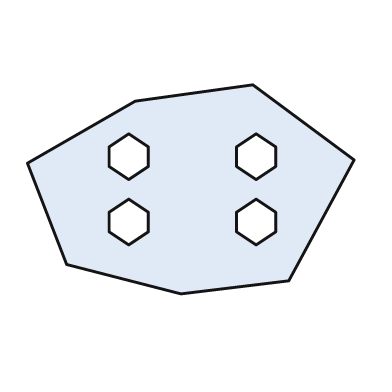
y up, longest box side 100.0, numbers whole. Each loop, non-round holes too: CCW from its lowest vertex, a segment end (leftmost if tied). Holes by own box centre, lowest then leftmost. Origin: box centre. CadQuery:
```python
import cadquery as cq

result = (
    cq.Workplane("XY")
    .moveTo(-3.0, -32.0)
    .lineTo(30.0, -28.0)
    .lineTo(50.0, 9.0)
    .lineTo(19.0, 32.0)
    .lineTo(-17.0, 27.0)
    .lineTo(-50.0, 8.0)
    .lineTo(-38.0, -23.0)
    .close()
    .moveTo(-19.0, -17.0)
    .lineTo(-13.0, -13.0)
    .lineTo(-13.0, -7.0)
    .lineTo(-19.0, -3.0)
    .lineTo(-25.0, -7.0)
    .lineTo(-25.0, -13.0)
    .close()
    .moveTo(20.0, -17.0)
    .lineTo(26.0, -13.0)
    .lineTo(26.0, -7.0)
    .lineTo(20.0, -3.0)
    .lineTo(14.0, -7.0)
    .lineTo(14.0, -13.0)
    .close()
    .moveTo(-19.0, 3.0)
    .lineTo(-13.0, 7.0)
    .lineTo(-13.0, 13.0)
    .lineTo(-19.0, 17.0)
    .lineTo(-25.0, 13.0)
    .lineTo(-25.0, 7.0)
    .close()
    .moveTo(20.0, 3.0)
    .lineTo(26.0, 7.0)
    .lineTo(26.0, 13.0)
    .lineTo(20.0, 17.0)
    .lineTo(14.0, 13.0)
    .lineTo(14.0, 7.0)
    .close()
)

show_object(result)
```